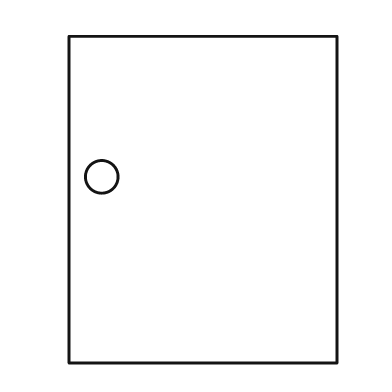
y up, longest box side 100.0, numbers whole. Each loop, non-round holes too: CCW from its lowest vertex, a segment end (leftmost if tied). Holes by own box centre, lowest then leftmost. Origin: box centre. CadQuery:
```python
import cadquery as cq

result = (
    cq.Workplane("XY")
    .moveTo(-41.0, -50.0)
    .lineTo(41.0, -50.0)
    .lineTo(41.0, 50.0)
    .lineTo(-41.0, 50.0)
    .close()
    .moveTo(-31.0, 7.0)
    .circle(5.0)
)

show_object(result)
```